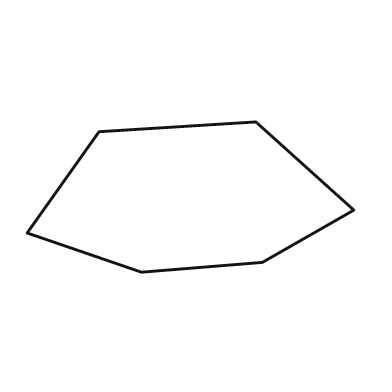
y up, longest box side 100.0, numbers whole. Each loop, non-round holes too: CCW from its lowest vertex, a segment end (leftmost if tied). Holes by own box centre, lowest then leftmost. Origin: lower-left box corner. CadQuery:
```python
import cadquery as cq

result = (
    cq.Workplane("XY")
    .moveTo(35.0, 0.0)
    .lineTo(72.0, 3.0)
    .lineTo(100.0, 19.0)
    .lineTo(70.0, 46.0)
    .lineTo(22.0, 43.0)
    .lineTo(0.0, 12.0)
    .close()
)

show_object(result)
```